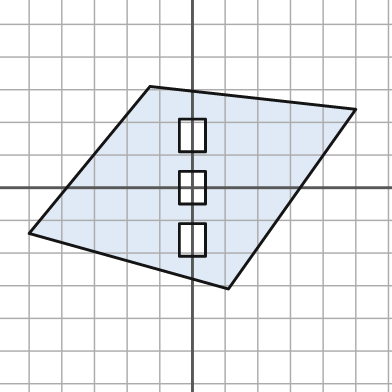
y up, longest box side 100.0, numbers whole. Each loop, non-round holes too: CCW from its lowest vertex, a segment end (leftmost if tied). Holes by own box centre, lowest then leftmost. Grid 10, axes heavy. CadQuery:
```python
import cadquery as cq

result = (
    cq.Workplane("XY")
    .moveTo(11.0, -31.0)
    .lineTo(50.0, 24.0)
    .lineTo(-13.0, 31.0)
    .lineTo(-50.0, -14.0)
    .close()
    .moveTo(-4.0, -21.0)
    .lineTo(4.0, -21.0)
    .lineTo(4.0, -11.0)
    .lineTo(-4.0, -11.0)
    .close()
    .moveTo(-4.0, -5.0)
    .lineTo(4.0, -5.0)
    .lineTo(4.0, 5.0)
    .lineTo(-4.0, 5.0)
    .close()
    .moveTo(-4.0, 11.0)
    .lineTo(4.0, 11.0)
    .lineTo(4.0, 21.0)
    .lineTo(-4.0, 21.0)
    .close()
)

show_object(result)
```